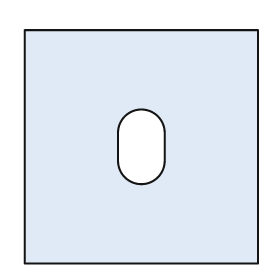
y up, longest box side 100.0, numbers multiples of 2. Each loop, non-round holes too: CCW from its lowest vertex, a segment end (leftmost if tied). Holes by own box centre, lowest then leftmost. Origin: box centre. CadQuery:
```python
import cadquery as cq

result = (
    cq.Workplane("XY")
    .moveTo(-50.0, -50.0)
    .lineTo(50.0, -50.0)
    .lineTo(50.0, 50.0)
    .lineTo(-50.0, 50.0)
    .close()
    .moveTo(-10.0, -6.0)
    .threePointArc((0.0, -16.0), (10.0, -6.0))
    .lineTo(10.0, 6.0)
    .threePointArc((0.0, 16.0), (-10.0, 6.0))
    .close()
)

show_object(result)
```